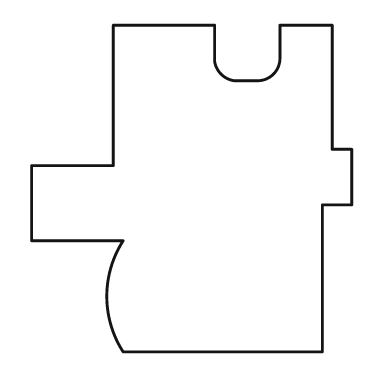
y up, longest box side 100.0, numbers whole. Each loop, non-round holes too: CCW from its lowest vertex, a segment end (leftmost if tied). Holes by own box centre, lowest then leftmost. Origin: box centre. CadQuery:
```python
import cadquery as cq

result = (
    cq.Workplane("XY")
    .moveTo(-21.0, -50.0)
    .lineTo(40.0, -50.0)
    .lineTo(40.0, -5.0)
    .lineTo(49.0, -5.0)
    .lineTo(49.0, 12.0)
    .lineTo(43.0, 12.0)
    .lineTo(43.0, 50.0)
    .lineTo(27.0, 50.0)
    .lineTo(27.0, 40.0)
    .threePointArc((25.0, 35.0), (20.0, 33.0))
    .lineTo(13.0, 33.0)
    .threePointArc((9.0, 35.0), (7.0, 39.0))
    .lineTo(7.0, 50.0)
    .lineTo(-24.0, 50.0)
    .lineTo(-24.0, 7.0)
    .lineTo(-49.0, 7.0)
    .lineTo(-49.0, -16.0)
    .lineTo(-21.0, -16.0)
    .threePointArc((-26.0, -33.0), (-21.0, -50.0))
    .close()
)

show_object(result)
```